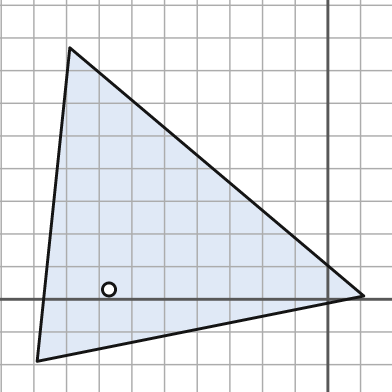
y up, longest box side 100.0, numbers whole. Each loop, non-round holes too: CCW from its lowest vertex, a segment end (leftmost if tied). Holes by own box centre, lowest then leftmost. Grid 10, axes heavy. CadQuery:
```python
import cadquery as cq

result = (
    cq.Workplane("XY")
    .moveTo(-89.0, -19.0)
    .lineTo(11.0, 1.0)
    .lineTo(-79.0, 77.0)
    .close()
    .moveTo(-67.0, 3.0)
    .circle(2.0)
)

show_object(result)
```